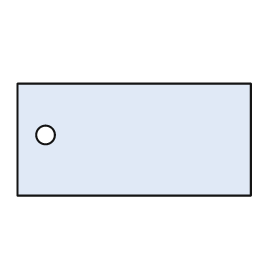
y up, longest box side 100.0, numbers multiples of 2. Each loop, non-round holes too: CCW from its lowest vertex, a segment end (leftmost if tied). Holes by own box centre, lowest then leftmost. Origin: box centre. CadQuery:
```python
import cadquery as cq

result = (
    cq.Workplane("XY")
    .moveTo(-50.0, -24.0)
    .lineTo(50.0, -24.0)
    .lineTo(50.0, 24.0)
    .lineTo(-50.0, 24.0)
    .close()
    .moveTo(-38.0, 2.0)
    .circle(4.0)
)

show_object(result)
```